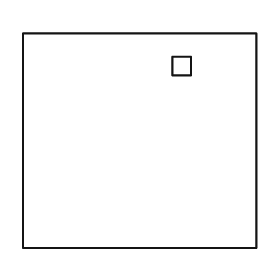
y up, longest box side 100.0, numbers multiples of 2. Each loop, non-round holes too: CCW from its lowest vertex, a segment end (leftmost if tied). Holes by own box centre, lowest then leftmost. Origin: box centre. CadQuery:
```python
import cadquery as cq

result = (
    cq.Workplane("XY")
    .moveTo(-50.0, -46.0)
    .lineTo(50.0, -46.0)
    .lineTo(50.0, 46.0)
    .lineTo(-50.0, 46.0)
    .close()
    .moveTo(14.0, 28.0)
    .lineTo(22.0, 28.0)
    .lineTo(22.0, 36.0)
    .lineTo(14.0, 36.0)
    .close()
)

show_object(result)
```